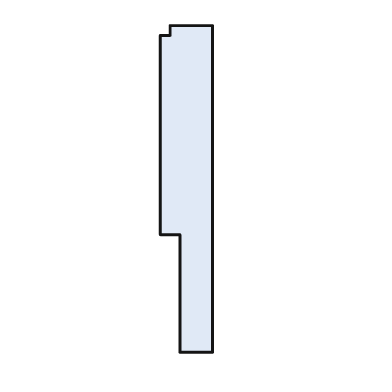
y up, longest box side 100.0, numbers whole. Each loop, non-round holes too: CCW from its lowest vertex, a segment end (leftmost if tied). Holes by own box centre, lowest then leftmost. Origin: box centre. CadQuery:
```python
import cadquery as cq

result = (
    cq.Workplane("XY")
    .moveTo(-2.0, -50.0)
    .lineTo(8.0, -50.0)
    .lineTo(8.0, 50.0)
    .lineTo(-5.0, 50.0)
    .lineTo(-5.0, 47.0)
    .lineTo(-8.0, 47.0)
    .lineTo(-8.0, -14.0)
    .lineTo(-2.0, -14.0)
    .close()
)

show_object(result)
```